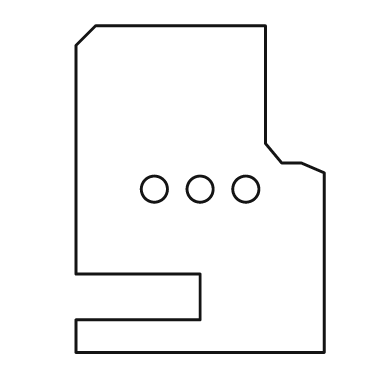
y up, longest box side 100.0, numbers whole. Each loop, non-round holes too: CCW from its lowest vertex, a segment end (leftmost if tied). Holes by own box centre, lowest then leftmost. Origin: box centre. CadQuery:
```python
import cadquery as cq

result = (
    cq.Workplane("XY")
    .moveTo(-38.0, -50.0)
    .lineTo(38.0, -50.0)
    .lineTo(38.0, 5.0)
    .lineTo(31.0, 8.0)
    .lineTo(25.0, 8.0)
    .lineTo(20.0, 14.0)
    .lineTo(20.0, 50.0)
    .lineTo(-32.0, 50.0)
    .lineTo(-38.0, 44.0)
    .lineTo(-38.0, -26.0)
    .lineTo(0.0, -26.0)
    .lineTo(0.0, -40.0)
    .lineTo(-38.0, -40.0)
    .close()
    .moveTo(-14.0, 0.0)
    .circle(4.0)
    .moveTo(0.0, 0.0)
    .circle(4.0)
    .moveTo(14.0, 0.0)
    .circle(4.0)
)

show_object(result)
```